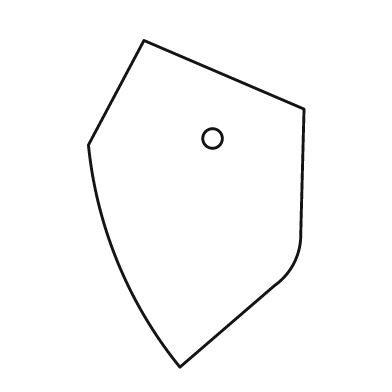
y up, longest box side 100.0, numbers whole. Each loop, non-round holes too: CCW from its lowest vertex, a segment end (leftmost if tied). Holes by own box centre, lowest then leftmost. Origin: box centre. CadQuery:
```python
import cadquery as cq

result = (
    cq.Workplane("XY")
    .moveTo(-5.0, -50.0)
    .lineTo(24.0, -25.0)
    .threePointArc((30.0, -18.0), (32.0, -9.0))
    .lineTo(33.0, 29.0)
    .lineTo(-16.0, 50.0)
    .lineTo(-33.0, 18.0)
    .threePointArc((-24.0, -18.0), (-5.0, -50.0))
    .close()
    .moveTo(5.0, 20.0)
    .circle(3.0)
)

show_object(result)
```